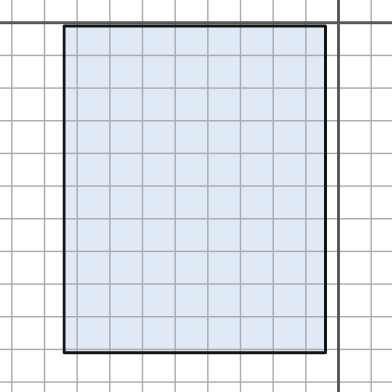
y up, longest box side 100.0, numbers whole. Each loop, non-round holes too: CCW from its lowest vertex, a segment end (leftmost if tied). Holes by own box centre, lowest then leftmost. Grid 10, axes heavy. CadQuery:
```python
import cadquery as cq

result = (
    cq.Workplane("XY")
    .moveTo(-84.0, -101.0)
    .lineTo(-4.0, -101.0)
    .lineTo(-4.0, -1.0)
    .lineTo(-84.0, -1.0)
    .close()
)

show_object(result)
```